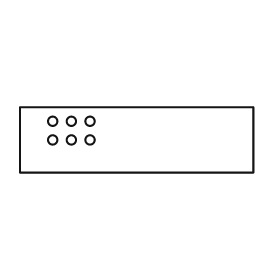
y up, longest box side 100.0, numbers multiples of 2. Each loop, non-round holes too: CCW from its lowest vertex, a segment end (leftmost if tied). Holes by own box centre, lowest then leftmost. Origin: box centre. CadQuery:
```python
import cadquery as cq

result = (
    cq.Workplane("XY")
    .moveTo(-50.0, -14.0)
    .lineTo(50.0, -14.0)
    .lineTo(50.0, 14.0)
    .lineTo(-50.0, 14.0)
    .close()
    .moveTo(-36.0, 0.0)
    .circle(2.0)
    .moveTo(-28.0, 0.0)
    .circle(2.0)
    .moveTo(-20.0, 0.0)
    .circle(2.0)
    .moveTo(-36.0, 8.0)
    .circle(2.0)
    .moveTo(-28.0, 8.0)
    .circle(2.0)
    .moveTo(-20.0, 8.0)
    .circle(2.0)
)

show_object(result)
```